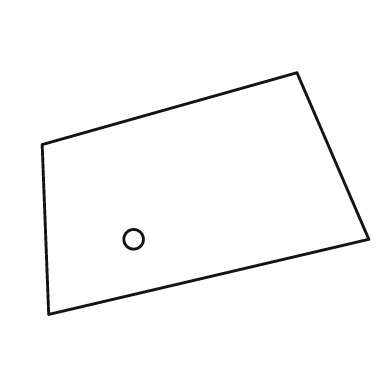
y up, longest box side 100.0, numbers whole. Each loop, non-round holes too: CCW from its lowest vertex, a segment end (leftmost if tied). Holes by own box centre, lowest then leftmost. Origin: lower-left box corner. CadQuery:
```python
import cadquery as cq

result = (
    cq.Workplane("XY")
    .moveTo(2.0, 0.0)
    .lineTo(100.0, 23.0)
    .lineTo(78.0, 74.0)
    .lineTo(0.0, 52.0)
    .close()
    .moveTo(28.0, 23.0)
    .circle(3.0)
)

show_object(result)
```